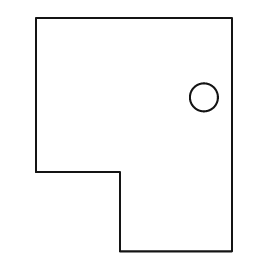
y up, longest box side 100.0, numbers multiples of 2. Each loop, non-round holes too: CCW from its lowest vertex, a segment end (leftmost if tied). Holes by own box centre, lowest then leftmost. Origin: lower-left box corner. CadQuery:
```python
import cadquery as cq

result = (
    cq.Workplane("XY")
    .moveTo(36.0, 0.0)
    .lineTo(84.0, 0.0)
    .lineTo(84.0, 100.0)
    .lineTo(0.0, 100.0)
    .lineTo(0.0, 34.0)
    .lineTo(36.0, 34.0)
    .close()
    .moveTo(72.0, 66.0)
    .circle(6.0)
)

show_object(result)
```